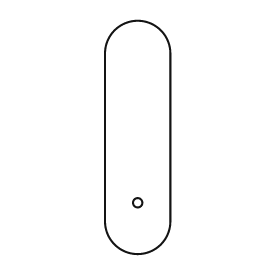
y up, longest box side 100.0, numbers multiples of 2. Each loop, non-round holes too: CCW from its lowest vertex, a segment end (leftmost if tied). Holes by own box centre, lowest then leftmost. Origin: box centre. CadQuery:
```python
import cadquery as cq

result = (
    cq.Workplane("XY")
    .moveTo(-14.0, -36.0)
    .threePointArc((0.0, -50.0), (14.0, -36.0))
    .lineTo(14.0, 36.0)
    .threePointArc((0.0, 50.0), (-14.0, 36.0))
    .close()
    .moveTo(0.0, -28.0)
    .circle(2.0)
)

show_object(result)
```